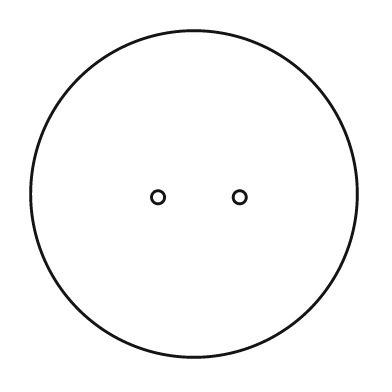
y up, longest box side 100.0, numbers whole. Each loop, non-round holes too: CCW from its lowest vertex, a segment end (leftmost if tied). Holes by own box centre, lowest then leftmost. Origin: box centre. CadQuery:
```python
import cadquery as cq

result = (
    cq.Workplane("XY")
    .moveTo(0.0, 0.0)
    .circle(50.0)
    .moveTo(-11.0, -1.0)
    .circle(2.0)
    .moveTo(14.0, -1.0)
    .circle(2.0)
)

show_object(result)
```